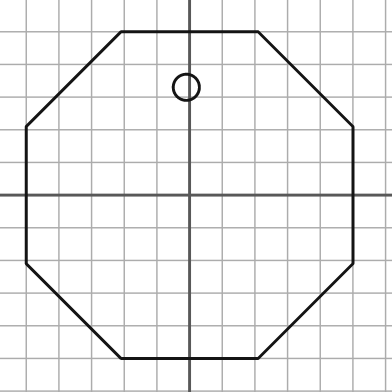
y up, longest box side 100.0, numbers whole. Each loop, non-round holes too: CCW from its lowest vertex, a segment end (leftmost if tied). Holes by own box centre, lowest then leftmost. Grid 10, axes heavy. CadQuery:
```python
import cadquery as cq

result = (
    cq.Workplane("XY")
    .moveTo(-21.0, -50.0)
    .lineTo(21.0, -50.0)
    .lineTo(50.0, -21.0)
    .lineTo(50.0, 21.0)
    .lineTo(21.0, 50.0)
    .lineTo(-21.0, 50.0)
    .lineTo(-50.0, 21.0)
    .lineTo(-50.0, -21.0)
    .close()
    .moveTo(-1.0, 33.0)
    .circle(4.0)
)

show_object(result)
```